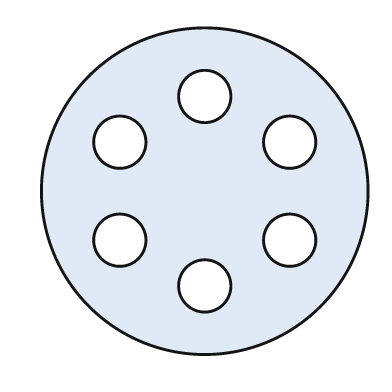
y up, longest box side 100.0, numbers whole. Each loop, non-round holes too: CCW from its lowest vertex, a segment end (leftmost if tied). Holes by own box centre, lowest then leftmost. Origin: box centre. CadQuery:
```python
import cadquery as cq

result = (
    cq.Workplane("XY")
    .moveTo(0.0, 0.0)
    .circle(50.0)
    .moveTo(0.0, -29.0)
    .circle(8.0)
    .moveTo(-26.0, -15.0)
    .circle(8.0)
    .moveTo(26.0, -15.0)
    .circle(8.0)
    .moveTo(-26.0, 15.0)
    .circle(8.0)
    .moveTo(26.0, 15.0)
    .circle(8.0)
    .moveTo(0.0, 29.0)
    .circle(8.0)
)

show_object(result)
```